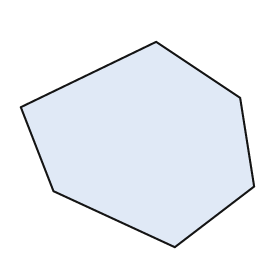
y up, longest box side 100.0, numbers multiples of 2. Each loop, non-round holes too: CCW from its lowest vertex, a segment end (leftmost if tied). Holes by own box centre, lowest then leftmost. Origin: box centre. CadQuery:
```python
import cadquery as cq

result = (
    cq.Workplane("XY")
    .moveTo(16.0, -44.0)
    .lineTo(50.0, -18.0)
    .lineTo(44.0, 20.0)
    .lineTo(8.0, 44.0)
    .lineTo(-50.0, 16.0)
    .lineTo(-36.0, -20.0)
    .close()
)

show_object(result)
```